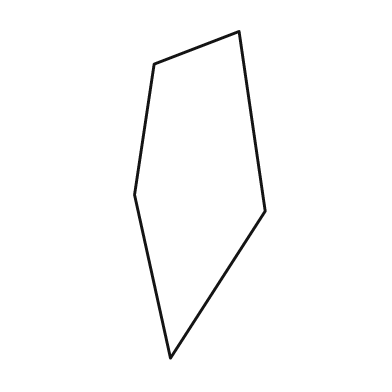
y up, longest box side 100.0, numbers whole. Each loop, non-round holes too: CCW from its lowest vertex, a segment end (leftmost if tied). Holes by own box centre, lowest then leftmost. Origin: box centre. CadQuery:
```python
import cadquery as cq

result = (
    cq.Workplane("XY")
    .moveTo(-9.0, -50.0)
    .lineTo(20.0, -5.0)
    .lineTo(12.0, 50.0)
    .lineTo(-14.0, 40.0)
    .lineTo(-20.0, 0.0)
    .close()
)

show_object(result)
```